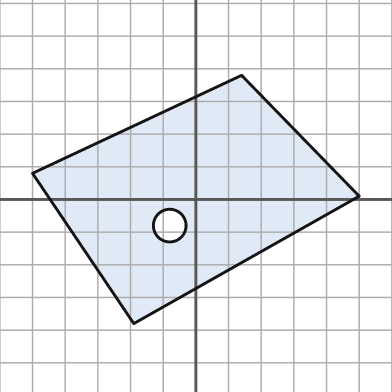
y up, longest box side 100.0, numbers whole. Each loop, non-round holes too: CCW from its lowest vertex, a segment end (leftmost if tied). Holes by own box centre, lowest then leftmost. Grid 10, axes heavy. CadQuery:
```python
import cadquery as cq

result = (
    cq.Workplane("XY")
    .moveTo(-19.0, -38.0)
    .lineTo(50.0, 1.0)
    .lineTo(14.0, 38.0)
    .lineTo(-50.0, 8.0)
    .close()
    .moveTo(-8.0, -8.0)
    .circle(5.0)
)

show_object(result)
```